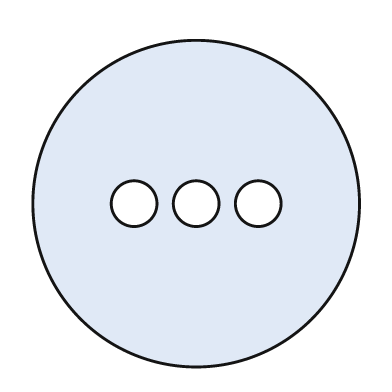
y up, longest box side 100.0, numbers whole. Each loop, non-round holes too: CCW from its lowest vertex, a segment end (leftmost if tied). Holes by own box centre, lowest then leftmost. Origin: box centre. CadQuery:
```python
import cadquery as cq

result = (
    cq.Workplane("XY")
    .moveTo(0.0, 0.0)
    .circle(50.0)
    .moveTo(-19.0, 0.0)
    .circle(7.0)
    .moveTo(0.0, 0.0)
    .circle(7.0)
    .moveTo(19.0, 0.0)
    .circle(7.0)
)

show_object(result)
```